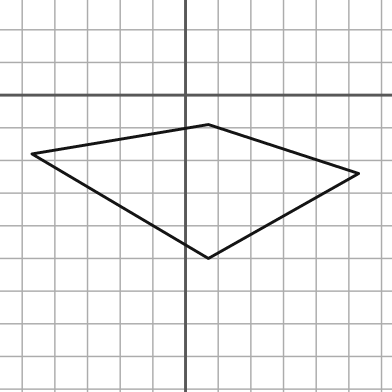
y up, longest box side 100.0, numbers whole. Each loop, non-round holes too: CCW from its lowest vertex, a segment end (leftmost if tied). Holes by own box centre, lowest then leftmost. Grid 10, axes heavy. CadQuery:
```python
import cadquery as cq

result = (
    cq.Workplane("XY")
    .moveTo(7.0, -50.0)
    .lineTo(53.0, -24.0)
    .lineTo(7.0, -9.0)
    .lineTo(-47.0, -18.0)
    .close()
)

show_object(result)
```